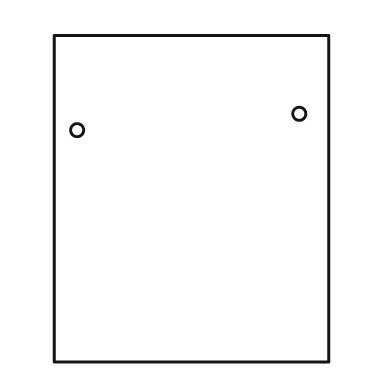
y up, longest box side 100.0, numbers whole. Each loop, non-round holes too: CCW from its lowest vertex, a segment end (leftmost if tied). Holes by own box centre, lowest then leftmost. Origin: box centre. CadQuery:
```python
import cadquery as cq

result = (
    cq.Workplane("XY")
    .moveTo(-42.0, -50.0)
    .lineTo(42.0, -50.0)
    .lineTo(42.0, 50.0)
    .lineTo(-42.0, 50.0)
    .close()
    .moveTo(-35.0, 21.0)
    .circle(2.0)
    .moveTo(33.0, 26.0)
    .circle(2.0)
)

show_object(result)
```